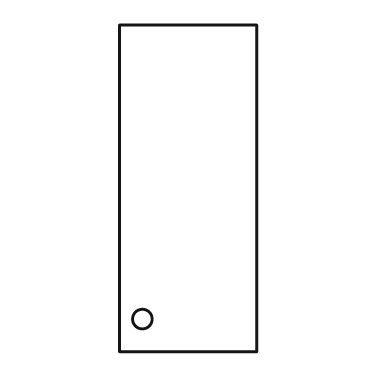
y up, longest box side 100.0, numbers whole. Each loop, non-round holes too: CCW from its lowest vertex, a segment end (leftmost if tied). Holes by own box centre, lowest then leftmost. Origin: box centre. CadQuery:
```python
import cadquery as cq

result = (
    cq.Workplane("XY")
    .moveTo(-21.0, -50.0)
    .lineTo(21.0, -50.0)
    .lineTo(21.0, 50.0)
    .lineTo(-21.0, 50.0)
    .close()
    .moveTo(-14.0, -40.0)
    .circle(3.0)
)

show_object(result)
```